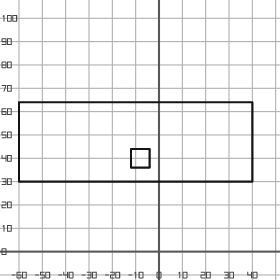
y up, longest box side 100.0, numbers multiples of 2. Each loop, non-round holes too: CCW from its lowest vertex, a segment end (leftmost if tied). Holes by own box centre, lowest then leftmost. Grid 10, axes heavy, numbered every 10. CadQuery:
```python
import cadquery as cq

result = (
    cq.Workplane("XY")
    .moveTo(-60.0, 30.0)
    .lineTo(40.0, 30.0)
    .lineTo(40.0, 64.0)
    .lineTo(-60.0, 64.0)
    .close()
    .moveTo(-12.0, 36.0)
    .lineTo(-4.0, 36.0)
    .lineTo(-4.0, 44.0)
    .lineTo(-12.0, 44.0)
    .close()
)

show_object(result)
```